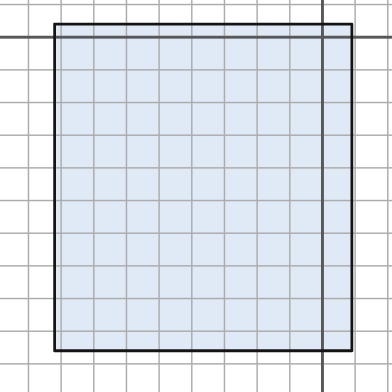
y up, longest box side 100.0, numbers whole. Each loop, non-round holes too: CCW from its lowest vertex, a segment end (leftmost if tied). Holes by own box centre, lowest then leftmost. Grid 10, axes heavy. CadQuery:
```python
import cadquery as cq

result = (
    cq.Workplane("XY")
    .moveTo(-82.0, -96.0)
    .lineTo(9.0, -96.0)
    .lineTo(9.0, 4.0)
    .lineTo(-82.0, 4.0)
    .close()
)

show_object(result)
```